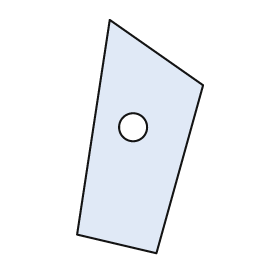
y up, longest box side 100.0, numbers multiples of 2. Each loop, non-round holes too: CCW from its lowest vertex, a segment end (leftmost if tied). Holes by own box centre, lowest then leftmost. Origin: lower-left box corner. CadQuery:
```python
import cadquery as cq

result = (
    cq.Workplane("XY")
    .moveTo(34.0, 0.0)
    .lineTo(54.0, 72.0)
    .lineTo(14.0, 100.0)
    .lineTo(0.0, 8.0)
    .close()
    .moveTo(24.0, 54.0)
    .circle(6.0)
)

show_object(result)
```